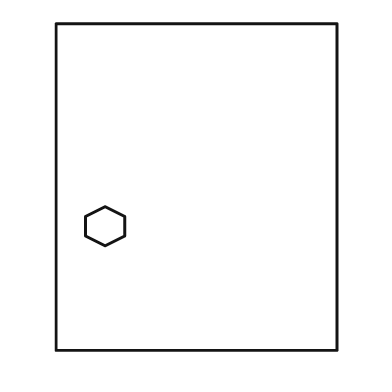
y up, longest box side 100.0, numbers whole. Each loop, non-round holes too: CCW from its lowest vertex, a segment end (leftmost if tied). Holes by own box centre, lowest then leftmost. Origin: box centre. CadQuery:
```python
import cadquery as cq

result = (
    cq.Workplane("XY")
    .moveTo(-43.0, -50.0)
    .lineTo(43.0, -50.0)
    .lineTo(43.0, 50.0)
    .lineTo(-43.0, 50.0)
    .close()
    .moveTo(-28.0, -18.0)
    .lineTo(-22.0, -15.0)
    .lineTo(-22.0, -9.0)
    .lineTo(-28.0, -6.0)
    .lineTo(-34.0, -9.0)
    .lineTo(-34.0, -15.0)
    .close()
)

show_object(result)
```